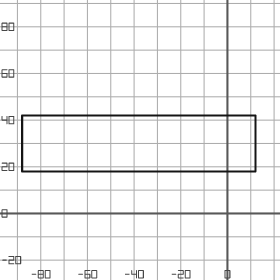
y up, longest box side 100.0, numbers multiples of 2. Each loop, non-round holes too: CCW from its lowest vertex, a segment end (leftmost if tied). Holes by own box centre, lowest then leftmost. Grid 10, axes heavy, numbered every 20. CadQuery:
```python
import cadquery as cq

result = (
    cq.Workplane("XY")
    .moveTo(-88.0, 18.0)
    .lineTo(12.0, 18.0)
    .lineTo(12.0, 42.0)
    .lineTo(-88.0, 42.0)
    .close()
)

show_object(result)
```